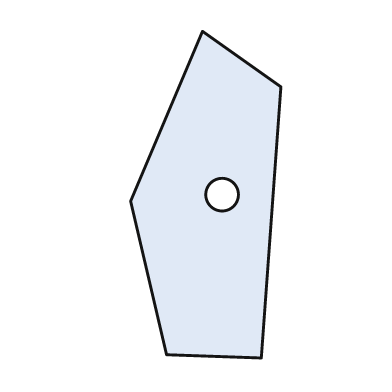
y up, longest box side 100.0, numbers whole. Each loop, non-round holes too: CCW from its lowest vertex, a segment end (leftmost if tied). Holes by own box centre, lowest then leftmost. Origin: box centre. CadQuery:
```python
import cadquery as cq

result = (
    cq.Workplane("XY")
    .moveTo(17.0, -50.0)
    .lineTo(23.0, 33.0)
    .lineTo(-1.0, 50.0)
    .lineTo(-23.0, -2.0)
    .lineTo(-12.0, -49.0)
    .close()
    .moveTo(5.0, 0.0)
    .circle(5.0)
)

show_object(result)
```